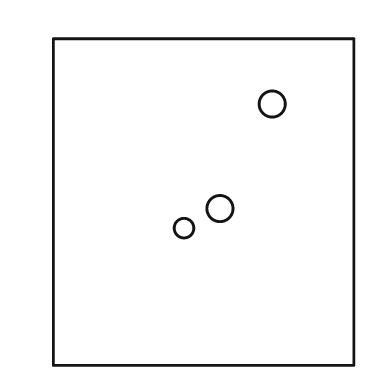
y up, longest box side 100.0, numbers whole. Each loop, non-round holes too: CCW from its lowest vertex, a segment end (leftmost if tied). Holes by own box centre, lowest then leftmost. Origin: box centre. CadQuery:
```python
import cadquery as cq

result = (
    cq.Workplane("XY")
    .moveTo(-46.0, -50.0)
    .lineTo(46.0, -50.0)
    .lineTo(46.0, 50.0)
    .lineTo(-46.0, 50.0)
    .close()
    .moveTo(-6.0, -8.0)
    .circle(3.0)
    .moveTo(5.0, -2.0)
    .circle(4.0)
    .moveTo(21.0, 30.0)
    .circle(4.0)
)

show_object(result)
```